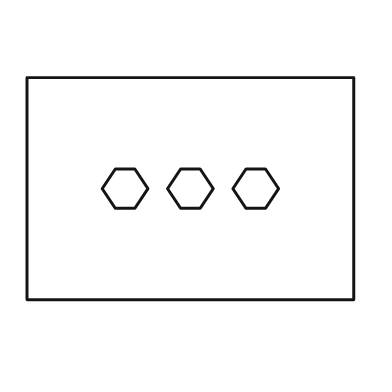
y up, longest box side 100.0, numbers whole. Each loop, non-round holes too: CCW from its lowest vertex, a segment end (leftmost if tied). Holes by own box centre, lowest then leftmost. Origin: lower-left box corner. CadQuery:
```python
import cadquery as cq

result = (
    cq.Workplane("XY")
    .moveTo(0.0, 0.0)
    .lineTo(100.0, 0.0)
    .lineTo(100.0, 68.0)
    .lineTo(0.0, 68.0)
    .close()
    .moveTo(27.0, 28.0)
    .lineTo(33.0, 28.0)
    .lineTo(37.0, 34.0)
    .lineTo(33.0, 40.0)
    .lineTo(27.0, 40.0)
    .lineTo(23.0, 34.0)
    .close()
    .moveTo(47.0, 28.0)
    .lineTo(53.0, 28.0)
    .lineTo(57.0, 34.0)
    .lineTo(53.0, 40.0)
    .lineTo(47.0, 40.0)
    .lineTo(43.0, 34.0)
    .close()
    .moveTo(67.0, 28.0)
    .lineTo(73.0, 28.0)
    .lineTo(77.0, 34.0)
    .lineTo(73.0, 40.0)
    .lineTo(67.0, 40.0)
    .lineTo(63.0, 34.0)
    .close()
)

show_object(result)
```